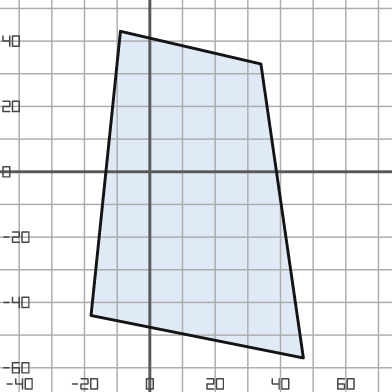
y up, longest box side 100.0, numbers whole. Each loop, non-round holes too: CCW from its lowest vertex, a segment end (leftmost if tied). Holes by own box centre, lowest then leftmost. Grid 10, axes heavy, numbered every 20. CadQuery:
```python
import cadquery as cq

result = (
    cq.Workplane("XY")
    .moveTo(47.0, -57.0)
    .lineTo(34.0, 33.0)
    .lineTo(-9.0, 43.0)
    .lineTo(-18.0, -44.0)
    .close()
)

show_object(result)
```